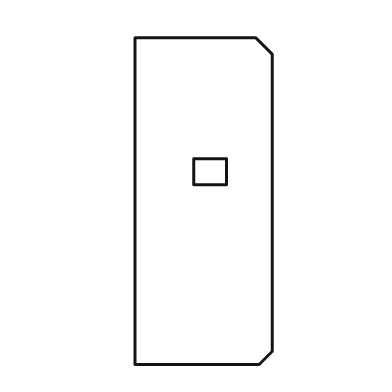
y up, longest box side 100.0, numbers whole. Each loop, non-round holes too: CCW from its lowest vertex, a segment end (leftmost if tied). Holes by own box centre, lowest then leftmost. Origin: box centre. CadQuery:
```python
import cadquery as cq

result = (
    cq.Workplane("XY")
    .moveTo(-21.0, -50.0)
    .lineTo(17.0, -50.0)
    .lineTo(21.0, -46.0)
    .lineTo(21.0, 45.0)
    .lineTo(16.0, 50.0)
    .lineTo(-21.0, 50.0)
    .close()
    .moveTo(-3.0, 5.0)
    .lineTo(7.0, 5.0)
    .lineTo(7.0, 13.0)
    .lineTo(-3.0, 13.0)
    .close()
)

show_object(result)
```